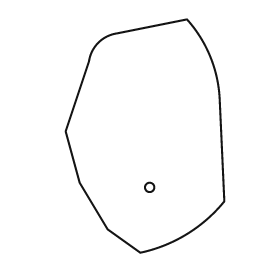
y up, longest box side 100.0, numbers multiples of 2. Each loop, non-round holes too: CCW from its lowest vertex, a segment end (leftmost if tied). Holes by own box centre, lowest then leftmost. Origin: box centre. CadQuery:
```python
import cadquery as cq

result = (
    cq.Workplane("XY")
    .moveTo(-2.0, -50.0)
    .threePointArc((18.0, -42.0), (34.0, -28.0))
    .lineTo(32.0, 16.0)
    .threePointArc((28.0, 34.0), (18.0, 50.0))
    .lineTo(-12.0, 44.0)
    .threePointArc((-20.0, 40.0), (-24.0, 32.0))
    .lineTo(-34.0, 2.0)
    .lineTo(-28.0, -20.0)
    .lineTo(-16.0, -40.0)
    .close()
    .moveTo(2.0, -22.0)
    .circle(2.0)
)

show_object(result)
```